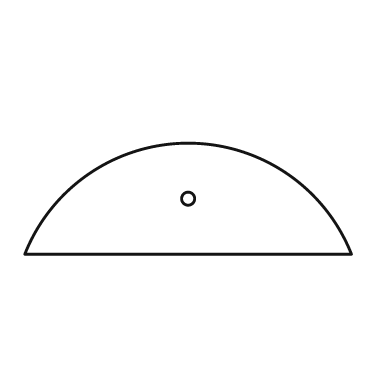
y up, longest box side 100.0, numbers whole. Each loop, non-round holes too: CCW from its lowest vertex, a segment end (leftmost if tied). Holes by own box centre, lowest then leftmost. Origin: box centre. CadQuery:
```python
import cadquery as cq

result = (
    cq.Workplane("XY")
    .moveTo(-50.0, -17.0)
    .lineTo(50.0, -17.0)
    .threePointArc((0.0, 17.0), (-50.0, -17.0))
    .close()
    .moveTo(0.0, 0.0)
    .circle(2.0)
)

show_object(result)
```